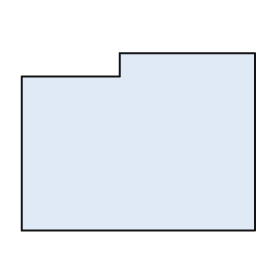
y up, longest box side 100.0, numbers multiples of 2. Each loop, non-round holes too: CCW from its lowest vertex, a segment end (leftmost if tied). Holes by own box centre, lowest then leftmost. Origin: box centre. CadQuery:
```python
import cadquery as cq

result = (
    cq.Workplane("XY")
    .moveTo(-50.0, -38.0)
    .lineTo(50.0, -38.0)
    .lineTo(50.0, 38.0)
    .lineTo(-8.0, 38.0)
    .lineTo(-8.0, 28.0)
    .lineTo(-50.0, 28.0)
    .close()
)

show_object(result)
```